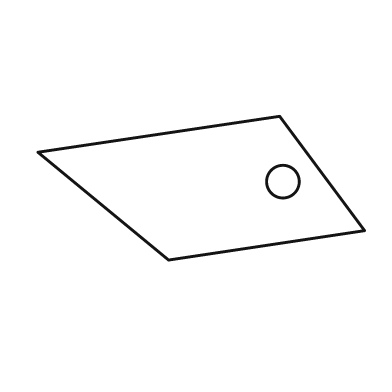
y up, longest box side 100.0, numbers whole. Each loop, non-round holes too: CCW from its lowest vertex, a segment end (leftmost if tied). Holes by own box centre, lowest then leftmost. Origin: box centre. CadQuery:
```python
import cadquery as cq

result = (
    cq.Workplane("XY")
    .moveTo(-10.0, -22.0)
    .lineTo(50.0, -13.0)
    .lineTo(24.0, 22.0)
    .lineTo(-50.0, 11.0)
    .close()
    .moveTo(25.0, 2.0)
    .circle(5.0)
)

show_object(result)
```